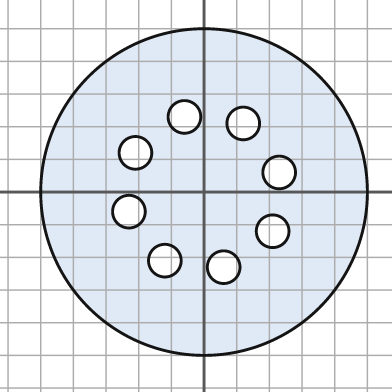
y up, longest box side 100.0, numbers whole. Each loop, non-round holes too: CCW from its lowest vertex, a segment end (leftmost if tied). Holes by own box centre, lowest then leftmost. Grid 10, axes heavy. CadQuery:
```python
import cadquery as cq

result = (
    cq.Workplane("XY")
    .moveTo(0.0, 0.0)
    .circle(50.0)
    .moveTo(6.0, -23.0)
    .circle(5.0)
    .moveTo(-12.0, -21.0)
    .circle(5.0)
    .moveTo(21.0, -12.0)
    .circle(5.0)
    .moveTo(-23.0, -6.0)
    .circle(5.0)
    .moveTo(23.0, 6.0)
    .circle(5.0)
    .moveTo(-21.0, 12.0)
    .circle(5.0)
    .moveTo(12.0, 21.0)
    .circle(5.0)
    .moveTo(-6.0, 23.0)
    .circle(5.0)
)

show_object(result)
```